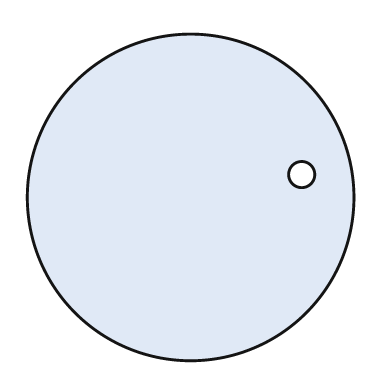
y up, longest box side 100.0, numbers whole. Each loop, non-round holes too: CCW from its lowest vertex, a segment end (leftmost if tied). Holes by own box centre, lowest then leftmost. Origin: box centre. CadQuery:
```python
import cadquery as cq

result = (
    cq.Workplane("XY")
    .moveTo(0.0, 0.0)
    .circle(50.0)
    .moveTo(34.0, 7.0)
    .circle(4.0)
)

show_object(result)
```